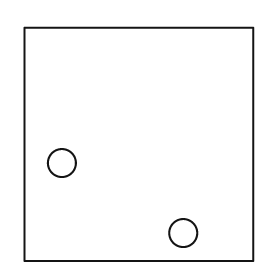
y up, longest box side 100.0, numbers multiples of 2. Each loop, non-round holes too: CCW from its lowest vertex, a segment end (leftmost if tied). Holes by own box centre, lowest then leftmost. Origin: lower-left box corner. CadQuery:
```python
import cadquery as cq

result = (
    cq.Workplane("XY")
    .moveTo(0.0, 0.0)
    .lineTo(98.0, 0.0)
    .lineTo(98.0, 100.0)
    .lineTo(0.0, 100.0)
    .close()
    .moveTo(68.0, 12.0)
    .circle(6.0)
    .moveTo(16.0, 42.0)
    .circle(6.0)
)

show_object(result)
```